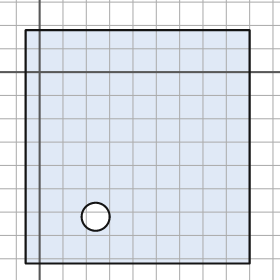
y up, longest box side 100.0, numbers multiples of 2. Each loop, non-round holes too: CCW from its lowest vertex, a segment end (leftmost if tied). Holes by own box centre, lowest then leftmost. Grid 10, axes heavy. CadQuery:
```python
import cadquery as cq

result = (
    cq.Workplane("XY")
    .moveTo(-6.0, -82.0)
    .lineTo(90.0, -82.0)
    .lineTo(90.0, 18.0)
    .lineTo(-6.0, 18.0)
    .close()
    .moveTo(24.0, -62.0)
    .circle(6.0)
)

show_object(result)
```